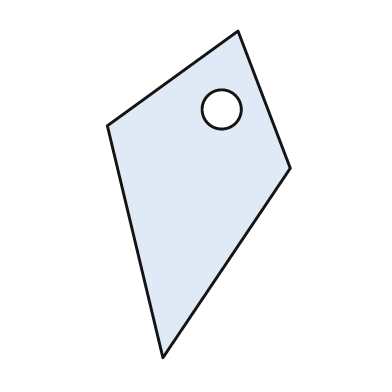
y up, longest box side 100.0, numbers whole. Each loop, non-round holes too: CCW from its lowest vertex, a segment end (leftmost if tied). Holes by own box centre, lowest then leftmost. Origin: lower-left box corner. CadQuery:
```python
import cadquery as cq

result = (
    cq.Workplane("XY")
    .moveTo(17.0, 0.0)
    .lineTo(56.0, 58.0)
    .lineTo(40.0, 100.0)
    .lineTo(0.0, 71.0)
    .close()
    .moveTo(35.0, 76.0)
    .circle(6.0)
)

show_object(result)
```